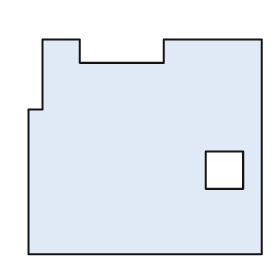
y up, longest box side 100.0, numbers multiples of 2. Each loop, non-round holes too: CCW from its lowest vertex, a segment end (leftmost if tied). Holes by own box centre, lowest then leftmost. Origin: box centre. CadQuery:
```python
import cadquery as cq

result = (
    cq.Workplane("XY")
    .moveTo(-50.0, -46.0)
    .lineTo(50.0, -46.0)
    .lineTo(50.0, 46.0)
    .lineTo(8.0, 46.0)
    .lineTo(8.0, 36.0)
    .lineTo(-28.0, 36.0)
    .lineTo(-28.0, 46.0)
    .lineTo(-44.0, 46.0)
    .lineTo(-44.0, 16.0)
    .lineTo(-50.0, 16.0)
    .close()
    .moveTo(26.0, -18.0)
    .lineTo(42.0, -18.0)
    .lineTo(42.0, -2.0)
    .lineTo(26.0, -2.0)
    .close()
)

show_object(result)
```